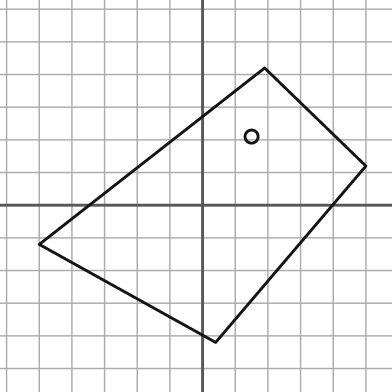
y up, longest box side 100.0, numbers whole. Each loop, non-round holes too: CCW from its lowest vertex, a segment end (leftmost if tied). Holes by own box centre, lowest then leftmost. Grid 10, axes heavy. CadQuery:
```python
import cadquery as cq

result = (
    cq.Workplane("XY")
    .moveTo(4.0, -42.0)
    .lineTo(50.0, 12.0)
    .lineTo(19.0, 42.0)
    .lineTo(-50.0, -12.0)
    .close()
    .moveTo(15.0, 21.0)
    .circle(2.0)
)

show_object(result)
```